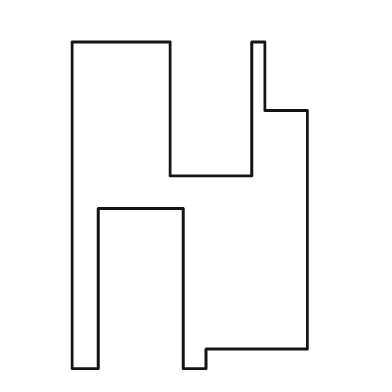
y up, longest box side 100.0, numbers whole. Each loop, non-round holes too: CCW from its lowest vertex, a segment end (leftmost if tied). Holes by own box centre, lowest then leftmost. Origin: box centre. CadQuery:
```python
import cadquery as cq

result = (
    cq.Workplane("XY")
    .moveTo(-36.0, -50.0)
    .lineTo(-28.0, -50.0)
    .lineTo(-28.0, -1.0)
    .lineTo(-2.0, -1.0)
    .lineTo(-2.0, -50.0)
    .lineTo(5.0, -50.0)
    .lineTo(5.0, -44.0)
    .lineTo(36.0, -44.0)
    .lineTo(36.0, 29.0)
    .lineTo(23.0, 29.0)
    .lineTo(23.0, 50.0)
    .lineTo(19.0, 50.0)
    .lineTo(19.0, 9.0)
    .lineTo(-6.0, 9.0)
    .lineTo(-6.0, 50.0)
    .lineTo(-36.0, 50.0)
    .close()
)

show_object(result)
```